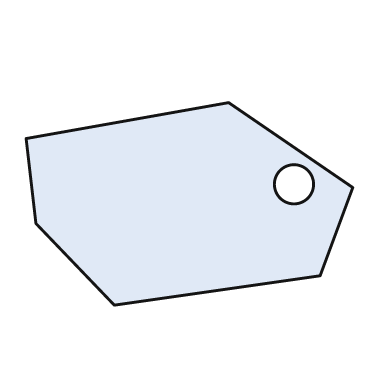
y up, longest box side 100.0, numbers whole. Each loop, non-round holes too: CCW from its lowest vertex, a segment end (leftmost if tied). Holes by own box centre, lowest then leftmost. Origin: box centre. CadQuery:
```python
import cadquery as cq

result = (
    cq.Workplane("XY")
    .moveTo(-23.0, -31.0)
    .lineTo(40.0, -22.0)
    .lineTo(50.0, 5.0)
    .lineTo(12.0, 31.0)
    .lineTo(-50.0, 20.0)
    .lineTo(-47.0, -6.0)
    .close()
    .moveTo(32.0, 6.0)
    .circle(6.0)
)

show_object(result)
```